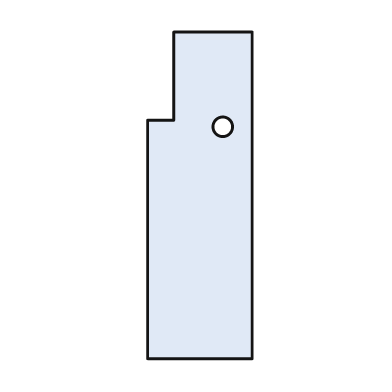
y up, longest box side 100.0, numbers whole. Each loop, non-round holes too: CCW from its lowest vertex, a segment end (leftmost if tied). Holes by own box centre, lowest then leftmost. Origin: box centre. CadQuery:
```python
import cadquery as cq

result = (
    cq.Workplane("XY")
    .moveTo(-16.0, -50.0)
    .lineTo(16.0, -50.0)
    .lineTo(16.0, 50.0)
    .lineTo(-8.0, 50.0)
    .lineTo(-8.0, 23.0)
    .lineTo(-16.0, 23.0)
    .close()
    .moveTo(7.0, 21.0)
    .circle(3.0)
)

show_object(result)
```